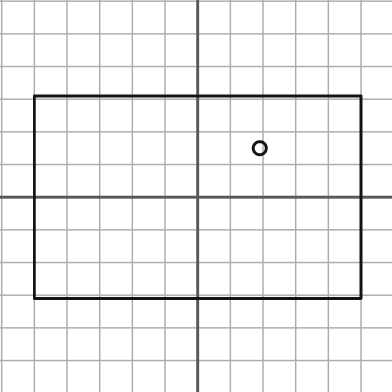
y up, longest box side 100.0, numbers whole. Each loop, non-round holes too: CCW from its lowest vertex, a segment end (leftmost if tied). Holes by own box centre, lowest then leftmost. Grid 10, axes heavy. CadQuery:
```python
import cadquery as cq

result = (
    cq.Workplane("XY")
    .moveTo(-50.0, -31.0)
    .lineTo(50.0, -31.0)
    .lineTo(50.0, 31.0)
    .lineTo(-50.0, 31.0)
    .close()
    .moveTo(19.0, 15.0)
    .circle(2.0)
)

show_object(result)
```